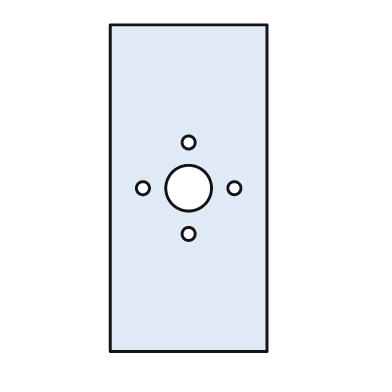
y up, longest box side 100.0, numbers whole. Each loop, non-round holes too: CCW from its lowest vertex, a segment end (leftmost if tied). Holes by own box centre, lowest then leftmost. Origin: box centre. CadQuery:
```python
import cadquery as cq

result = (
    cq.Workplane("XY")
    .moveTo(-24.0, -50.0)
    .lineTo(24.0, -50.0)
    .lineTo(24.0, 50.0)
    .lineTo(-24.0, 50.0)
    .close()
    .moveTo(0.0, -14.0)
    .circle(2.0)
    .moveTo(-14.0, 0.0)
    .circle(2.0)
    .moveTo(0.0, 0.0)
    .circle(7.0)
    .moveTo(14.0, 0.0)
    .circle(2.0)
    .moveTo(0.0, 14.0)
    .circle(2.0)
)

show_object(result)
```